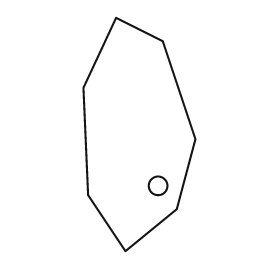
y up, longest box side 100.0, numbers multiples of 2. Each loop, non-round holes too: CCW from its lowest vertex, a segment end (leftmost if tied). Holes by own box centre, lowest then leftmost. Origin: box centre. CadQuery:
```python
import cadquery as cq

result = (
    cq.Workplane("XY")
    .moveTo(-6.0, -50.0)
    .lineTo(16.0, -32.0)
    .lineTo(24.0, -2.0)
    .lineTo(10.0, 40.0)
    .lineTo(-10.0, 50.0)
    .lineTo(-24.0, 20.0)
    .lineTo(-22.0, -26.0)
    .close()
    .moveTo(8.0, -22.0)
    .circle(4.0)
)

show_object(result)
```